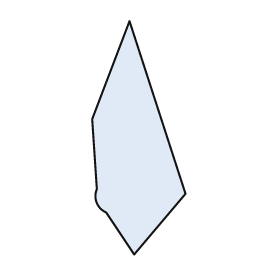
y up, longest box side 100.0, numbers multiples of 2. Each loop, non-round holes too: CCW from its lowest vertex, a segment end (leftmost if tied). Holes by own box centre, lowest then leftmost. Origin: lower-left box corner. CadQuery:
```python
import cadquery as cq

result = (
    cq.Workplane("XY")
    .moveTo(18.0, 0.0)
    .lineTo(40.0, 26.0)
    .lineTo(16.0, 100.0)
    .lineTo(0.0, 58.0)
    .lineTo(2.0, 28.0)
    .threePointArc((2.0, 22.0), (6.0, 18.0))
    .close()
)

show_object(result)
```